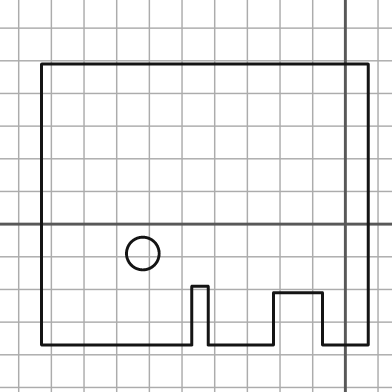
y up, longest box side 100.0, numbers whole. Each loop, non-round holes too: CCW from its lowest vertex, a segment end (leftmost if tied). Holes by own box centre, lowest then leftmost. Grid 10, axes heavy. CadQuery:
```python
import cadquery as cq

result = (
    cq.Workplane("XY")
    .moveTo(-93.0, -37.0)
    .lineTo(-47.0, -37.0)
    .lineTo(-47.0, -19.0)
    .lineTo(-42.0, -19.0)
    .lineTo(-42.0, -37.0)
    .lineTo(-22.0, -37.0)
    .lineTo(-22.0, -21.0)
    .lineTo(-7.0, -21.0)
    .lineTo(-7.0, -37.0)
    .lineTo(7.0, -37.0)
    .lineTo(7.0, 49.0)
    .lineTo(-93.0, 49.0)
    .close()
    .moveTo(-62.0, -9.0)
    .circle(5.0)
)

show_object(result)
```